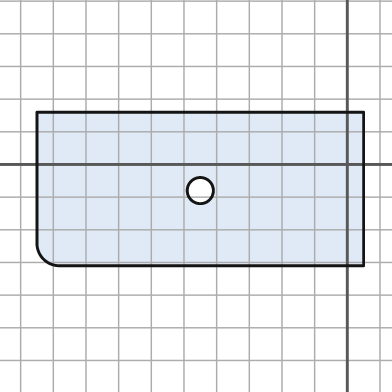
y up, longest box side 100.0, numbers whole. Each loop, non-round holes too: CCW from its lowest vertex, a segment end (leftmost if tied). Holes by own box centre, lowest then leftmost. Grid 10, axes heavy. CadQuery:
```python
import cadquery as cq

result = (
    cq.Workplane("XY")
    .moveTo(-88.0, -31.0)
    .lineTo(5.0, -31.0)
    .lineTo(5.0, 16.0)
    .lineTo(-95.0, 16.0)
    .lineTo(-95.0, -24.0)
    .threePointArc((-93.0, -29.0), (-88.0, -31.0))
    .close()
    .moveTo(-45.0, -8.0)
    .circle(4.0)
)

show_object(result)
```